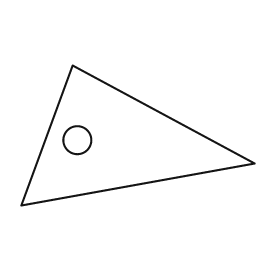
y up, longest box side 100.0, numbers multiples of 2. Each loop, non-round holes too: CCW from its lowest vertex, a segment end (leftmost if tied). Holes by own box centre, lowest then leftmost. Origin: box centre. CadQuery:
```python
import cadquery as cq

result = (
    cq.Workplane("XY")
    .moveTo(-50.0, -30.0)
    .lineTo(50.0, -12.0)
    .lineTo(-28.0, 30.0)
    .close()
    .moveTo(-26.0, -2.0)
    .circle(6.0)
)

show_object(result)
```